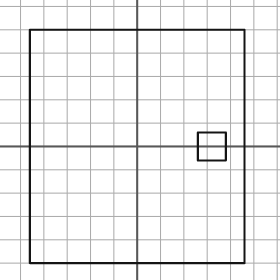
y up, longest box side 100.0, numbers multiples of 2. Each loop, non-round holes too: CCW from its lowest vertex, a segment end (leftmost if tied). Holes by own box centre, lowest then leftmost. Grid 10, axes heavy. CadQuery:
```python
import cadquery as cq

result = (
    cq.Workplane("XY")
    .moveTo(-46.0, -50.0)
    .lineTo(46.0, -50.0)
    .lineTo(46.0, 50.0)
    .lineTo(-46.0, 50.0)
    .close()
    .moveTo(26.0, -6.0)
    .lineTo(38.0, -6.0)
    .lineTo(38.0, 6.0)
    .lineTo(26.0, 6.0)
    .close()
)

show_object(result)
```